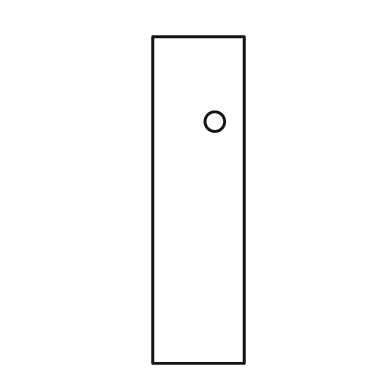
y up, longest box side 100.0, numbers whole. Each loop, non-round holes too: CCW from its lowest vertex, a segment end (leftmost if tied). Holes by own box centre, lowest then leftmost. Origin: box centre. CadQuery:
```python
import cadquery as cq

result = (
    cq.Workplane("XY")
    .moveTo(-14.0, -50.0)
    .lineTo(14.0, -50.0)
    .lineTo(14.0, 50.0)
    .lineTo(-14.0, 50.0)
    .close()
    .moveTo(5.0, 24.0)
    .circle(3.0)
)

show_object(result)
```